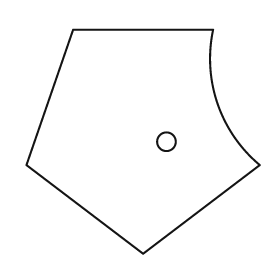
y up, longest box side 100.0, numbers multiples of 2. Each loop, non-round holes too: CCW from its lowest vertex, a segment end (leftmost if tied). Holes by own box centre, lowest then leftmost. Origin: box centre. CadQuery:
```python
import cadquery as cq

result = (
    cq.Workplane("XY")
    .moveTo(0.0, -48.0)
    .lineTo(50.0, -10.0)
    .threePointArc((32.0, 16.0), (30.0, 48.0))
    .lineTo(-30.0, 48.0)
    .lineTo(-50.0, -10.0)
    .close()
    .moveTo(10.0, 0.0)
    .circle(4.0)
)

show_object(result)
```